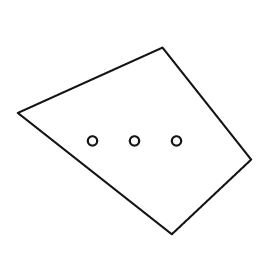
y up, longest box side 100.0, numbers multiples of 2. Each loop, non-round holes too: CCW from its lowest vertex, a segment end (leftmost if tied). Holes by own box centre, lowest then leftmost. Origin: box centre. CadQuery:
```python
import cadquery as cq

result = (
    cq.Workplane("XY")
    .moveTo(16.0, -40.0)
    .lineTo(50.0, -8.0)
    .lineTo(12.0, 40.0)
    .lineTo(-50.0, 12.0)
    .close()
    .moveTo(-18.0, 0.0)
    .circle(2.0)
    .moveTo(0.0, 0.0)
    .circle(2.0)
    .moveTo(18.0, 0.0)
    .circle(2.0)
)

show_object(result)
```